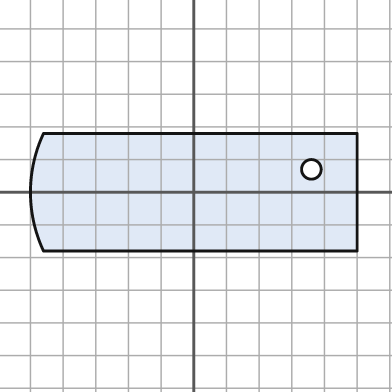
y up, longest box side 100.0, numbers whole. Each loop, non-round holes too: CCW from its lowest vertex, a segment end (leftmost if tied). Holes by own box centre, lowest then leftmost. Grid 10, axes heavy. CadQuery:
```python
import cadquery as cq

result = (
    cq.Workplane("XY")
    .moveTo(-46.0, -18.0)
    .lineTo(50.0, -18.0)
    .lineTo(50.0, 18.0)
    .lineTo(-46.0, 18.0)
    .threePointArc((-50.0, 0.0), (-46.0, -18.0))
    .close()
    .moveTo(36.0, 7.0)
    .circle(3.0)
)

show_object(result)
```